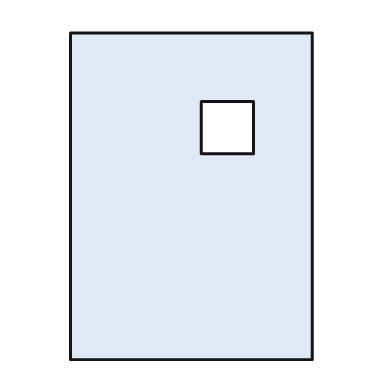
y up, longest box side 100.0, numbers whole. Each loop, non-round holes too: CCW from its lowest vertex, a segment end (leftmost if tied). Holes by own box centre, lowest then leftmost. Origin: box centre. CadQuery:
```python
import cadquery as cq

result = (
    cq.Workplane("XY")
    .moveTo(-37.0, -50.0)
    .lineTo(37.0, -50.0)
    .lineTo(37.0, 50.0)
    .lineTo(-37.0, 50.0)
    .close()
    .moveTo(3.0, 13.0)
    .lineTo(19.0, 13.0)
    .lineTo(19.0, 29.0)
    .lineTo(3.0, 29.0)
    .close()
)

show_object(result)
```